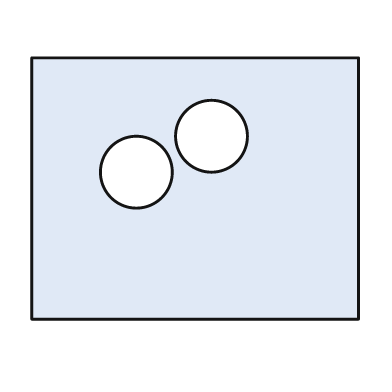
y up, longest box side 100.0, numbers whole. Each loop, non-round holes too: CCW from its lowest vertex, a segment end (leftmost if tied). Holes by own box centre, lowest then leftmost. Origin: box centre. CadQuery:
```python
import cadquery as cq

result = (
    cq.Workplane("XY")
    .moveTo(-50.0, -40.0)
    .lineTo(50.0, -40.0)
    .lineTo(50.0, 40.0)
    .lineTo(-50.0, 40.0)
    .close()
    .moveTo(-18.0, 5.0)
    .circle(11.0)
    .moveTo(5.0, 16.0)
    .circle(11.0)
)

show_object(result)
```